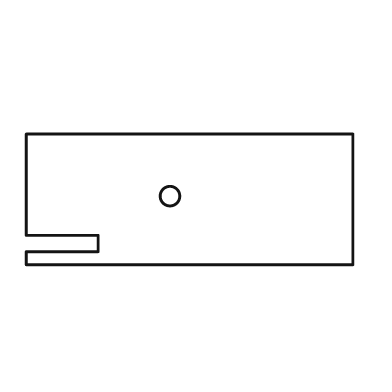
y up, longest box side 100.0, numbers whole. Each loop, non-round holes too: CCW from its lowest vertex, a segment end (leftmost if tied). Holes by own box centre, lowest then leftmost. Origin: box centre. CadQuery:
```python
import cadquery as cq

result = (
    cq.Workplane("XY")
    .moveTo(-50.0, -20.0)
    .lineTo(50.0, -20.0)
    .lineTo(50.0, 20.0)
    .lineTo(-50.0, 20.0)
    .lineTo(-50.0, -11.0)
    .lineTo(-28.0, -11.0)
    .lineTo(-28.0, -16.0)
    .lineTo(-50.0, -16.0)
    .close()
    .moveTo(-6.0, 1.0)
    .circle(3.0)
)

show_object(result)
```